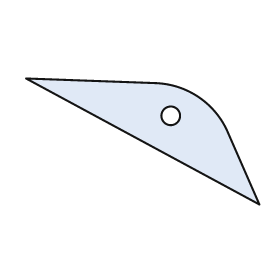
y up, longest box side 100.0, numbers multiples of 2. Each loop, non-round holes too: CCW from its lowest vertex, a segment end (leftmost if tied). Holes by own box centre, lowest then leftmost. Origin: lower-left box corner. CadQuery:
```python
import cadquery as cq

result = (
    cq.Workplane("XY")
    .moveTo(100.0, 0.0)
    .lineTo(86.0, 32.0)
    .threePointArc((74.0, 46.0), (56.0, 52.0))
    .lineTo(0.0, 54.0)
    .close()
    .moveTo(62.0, 38.0)
    .circle(4.0)
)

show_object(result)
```